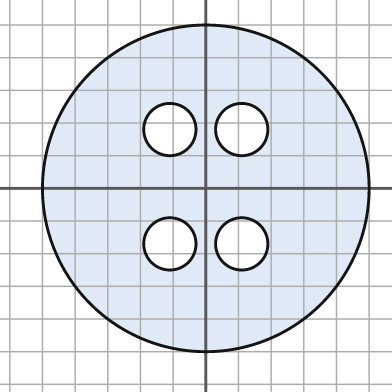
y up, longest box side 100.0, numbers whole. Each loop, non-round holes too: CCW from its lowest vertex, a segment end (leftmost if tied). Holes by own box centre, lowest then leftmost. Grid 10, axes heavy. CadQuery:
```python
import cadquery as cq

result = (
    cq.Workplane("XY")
    .moveTo(0.0, 0.0)
    .circle(50.0)
    .moveTo(-11.0, -17.0)
    .circle(8.0)
    .moveTo(11.0, -17.0)
    .circle(8.0)
    .moveTo(-11.0, 18.0)
    .circle(8.0)
    .moveTo(11.0, 18.0)
    .circle(8.0)
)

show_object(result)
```